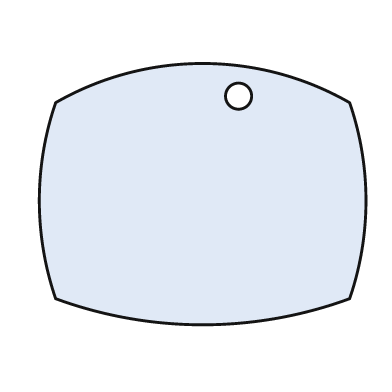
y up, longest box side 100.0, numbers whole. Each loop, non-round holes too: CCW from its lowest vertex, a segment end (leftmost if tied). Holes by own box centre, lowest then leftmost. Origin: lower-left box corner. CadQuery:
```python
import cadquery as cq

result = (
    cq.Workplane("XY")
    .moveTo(5.0, 8.0)
    .threePointArc((50.0, 0.0), (95.0, 8.0))
    .threePointArc((100.0, 38.0), (95.0, 68.0))
    .threePointArc((50.0, 80.0), (5.0, 68.0))
    .threePointArc((0.0, 38.0), (5.0, 8.0))
    .close()
    .moveTo(61.0, 70.0)
    .circle(4.0)
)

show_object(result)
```